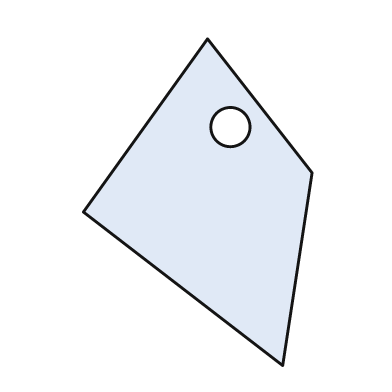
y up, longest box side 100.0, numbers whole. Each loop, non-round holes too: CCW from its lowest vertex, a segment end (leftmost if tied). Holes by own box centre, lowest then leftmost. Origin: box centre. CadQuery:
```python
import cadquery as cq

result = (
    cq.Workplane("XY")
    .moveTo(26.0, -50.0)
    .lineTo(35.0, 9.0)
    .lineTo(3.0, 50.0)
    .lineTo(-35.0, -3.0)
    .close()
    .moveTo(10.0, 23.0)
    .circle(6.0)
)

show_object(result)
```